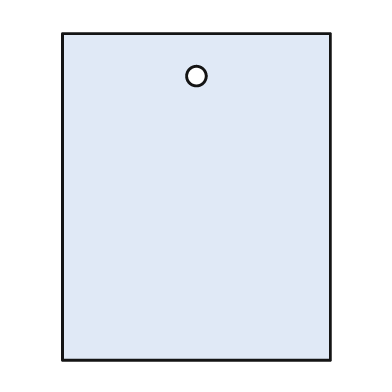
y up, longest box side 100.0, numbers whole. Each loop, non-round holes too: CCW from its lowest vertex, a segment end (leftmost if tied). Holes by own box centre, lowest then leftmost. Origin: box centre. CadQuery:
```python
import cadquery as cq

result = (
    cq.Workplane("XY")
    .moveTo(-41.0, -50.0)
    .lineTo(41.0, -50.0)
    .lineTo(41.0, 50.0)
    .lineTo(-41.0, 50.0)
    .close()
    .moveTo(0.0, 37.0)
    .circle(3.0)
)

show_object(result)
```